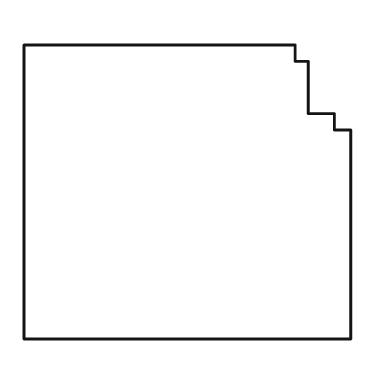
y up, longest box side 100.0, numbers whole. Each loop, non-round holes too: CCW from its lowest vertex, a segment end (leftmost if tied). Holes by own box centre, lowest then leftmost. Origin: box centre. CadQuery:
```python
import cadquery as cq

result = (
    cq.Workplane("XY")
    .moveTo(-50.0, -45.0)
    .lineTo(50.0, -45.0)
    .lineTo(50.0, 19.0)
    .lineTo(45.0, 19.0)
    .lineTo(45.0, 24.0)
    .lineTo(37.0, 24.0)
    .lineTo(37.0, 40.0)
    .lineTo(33.0, 40.0)
    .lineTo(33.0, 45.0)
    .lineTo(-50.0, 45.0)
    .close()
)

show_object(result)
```